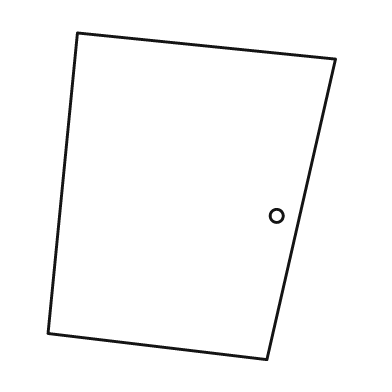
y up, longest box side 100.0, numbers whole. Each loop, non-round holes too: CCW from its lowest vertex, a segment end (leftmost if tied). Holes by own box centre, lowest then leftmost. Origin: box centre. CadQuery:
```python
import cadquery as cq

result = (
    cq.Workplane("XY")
    .moveTo(23.0, -50.0)
    .lineTo(44.0, 42.0)
    .lineTo(-35.0, 50.0)
    .lineTo(-44.0, -42.0)
    .close()
    .moveTo(26.0, -6.0)
    .circle(2.0)
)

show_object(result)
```